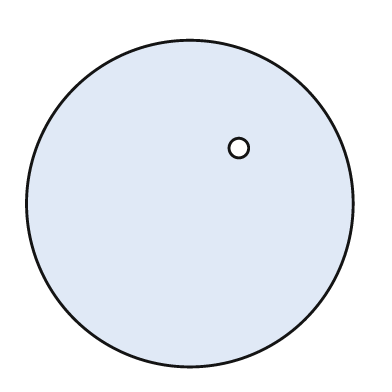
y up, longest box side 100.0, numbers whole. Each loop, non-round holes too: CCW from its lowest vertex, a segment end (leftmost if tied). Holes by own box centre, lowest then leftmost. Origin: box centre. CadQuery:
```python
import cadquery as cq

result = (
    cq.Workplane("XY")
    .moveTo(0.0, 0.0)
    .circle(50.0)
    .moveTo(15.0, 17.0)
    .circle(3.0)
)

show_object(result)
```